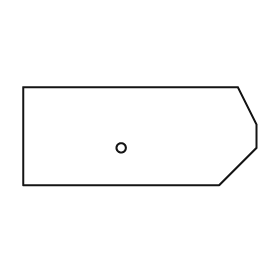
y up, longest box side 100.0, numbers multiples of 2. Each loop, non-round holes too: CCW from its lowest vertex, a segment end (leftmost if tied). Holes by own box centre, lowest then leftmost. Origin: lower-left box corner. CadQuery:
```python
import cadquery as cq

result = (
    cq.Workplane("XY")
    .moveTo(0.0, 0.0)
    .lineTo(84.0, 0.0)
    .lineTo(100.0, 16.0)
    .lineTo(100.0, 26.0)
    .lineTo(92.0, 42.0)
    .lineTo(0.0, 42.0)
    .close()
    .moveTo(42.0, 16.0)
    .circle(2.0)
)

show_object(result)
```